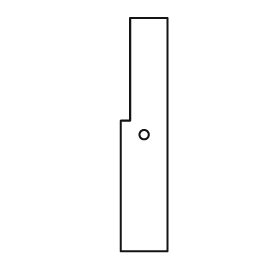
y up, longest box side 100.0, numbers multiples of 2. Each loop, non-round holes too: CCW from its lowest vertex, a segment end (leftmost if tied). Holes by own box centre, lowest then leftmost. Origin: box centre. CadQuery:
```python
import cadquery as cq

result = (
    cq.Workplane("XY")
    .moveTo(-10.0, -50.0)
    .lineTo(10.0, -50.0)
    .lineTo(10.0, 50.0)
    .lineTo(-6.0, 50.0)
    .lineTo(-6.0, 6.0)
    .lineTo(-10.0, 6.0)
    .close()
    .moveTo(0.0, 0.0)
    .circle(2.0)
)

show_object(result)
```